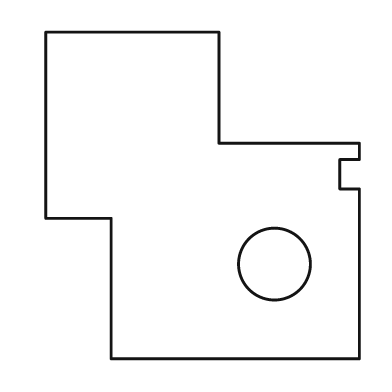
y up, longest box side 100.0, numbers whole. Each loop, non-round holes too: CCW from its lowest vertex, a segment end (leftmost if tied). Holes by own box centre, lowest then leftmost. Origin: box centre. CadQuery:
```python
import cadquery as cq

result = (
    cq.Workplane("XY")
    .moveTo(-28.0, -50.0)
    .lineTo(48.0, -50.0)
    .lineTo(48.0, 2.0)
    .lineTo(42.0, 2.0)
    .lineTo(42.0, 11.0)
    .lineTo(48.0, 11.0)
    .lineTo(48.0, 16.0)
    .lineTo(5.0, 16.0)
    .lineTo(5.0, 50.0)
    .lineTo(-48.0, 50.0)
    .lineTo(-48.0, -7.0)
    .lineTo(-28.0, -7.0)
    .close()
    .moveTo(22.0, -21.0)
    .circle(11.0)
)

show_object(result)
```